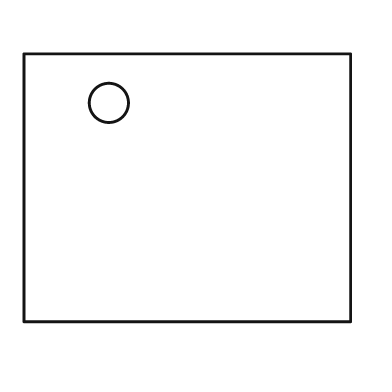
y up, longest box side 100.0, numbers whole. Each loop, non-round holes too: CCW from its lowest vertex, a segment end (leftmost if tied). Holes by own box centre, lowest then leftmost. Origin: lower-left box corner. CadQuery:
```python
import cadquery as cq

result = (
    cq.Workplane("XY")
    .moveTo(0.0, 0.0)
    .lineTo(100.0, 0.0)
    .lineTo(100.0, 82.0)
    .lineTo(0.0, 82.0)
    .close()
    .moveTo(26.0, 67.0)
    .circle(6.0)
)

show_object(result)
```